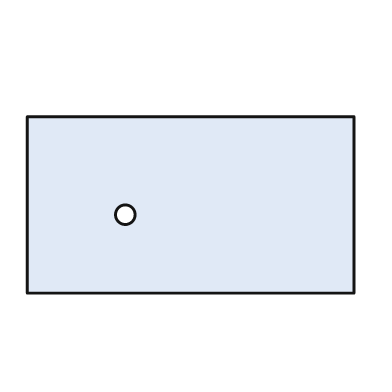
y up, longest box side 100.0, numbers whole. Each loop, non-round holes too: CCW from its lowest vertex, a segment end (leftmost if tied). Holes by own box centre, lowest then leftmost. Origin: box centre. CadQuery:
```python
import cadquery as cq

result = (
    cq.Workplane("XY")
    .moveTo(-50.0, -27.0)
    .lineTo(50.0, -27.0)
    .lineTo(50.0, 27.0)
    .lineTo(-50.0, 27.0)
    .close()
    .moveTo(-20.0, -3.0)
    .circle(3.0)
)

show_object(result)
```